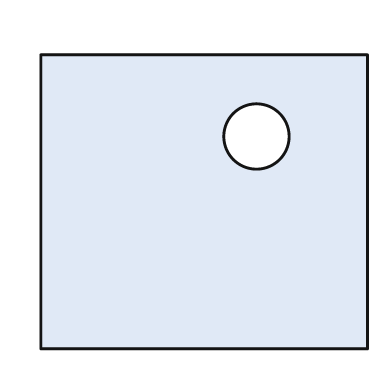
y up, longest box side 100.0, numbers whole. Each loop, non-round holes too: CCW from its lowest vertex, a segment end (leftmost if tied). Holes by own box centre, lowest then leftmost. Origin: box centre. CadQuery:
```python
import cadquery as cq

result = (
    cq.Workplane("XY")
    .moveTo(-50.0, -45.0)
    .lineTo(50.0, -45.0)
    .lineTo(50.0, 45.0)
    .lineTo(-50.0, 45.0)
    .close()
    .moveTo(16.0, 20.0)
    .circle(10.0)
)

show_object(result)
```